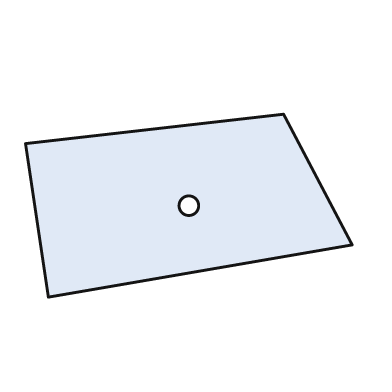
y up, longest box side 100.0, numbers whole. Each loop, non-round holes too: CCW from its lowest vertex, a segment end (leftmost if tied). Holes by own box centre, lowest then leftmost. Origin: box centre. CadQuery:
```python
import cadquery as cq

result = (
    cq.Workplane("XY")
    .moveTo(-43.0, -28.0)
    .lineTo(50.0, -12.0)
    .lineTo(29.0, 28.0)
    .lineTo(-50.0, 19.0)
    .close()
    .moveTo(0.0, 0.0)
    .circle(3.0)
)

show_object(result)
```